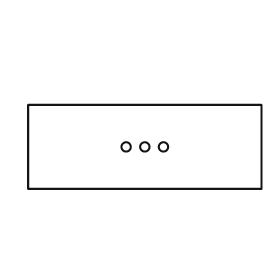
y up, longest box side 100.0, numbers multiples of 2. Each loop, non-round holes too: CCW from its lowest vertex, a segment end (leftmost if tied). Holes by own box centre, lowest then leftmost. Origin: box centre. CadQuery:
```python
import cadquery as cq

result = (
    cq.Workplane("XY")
    .moveTo(-50.0, -18.0)
    .lineTo(50.0, -18.0)
    .lineTo(50.0, 18.0)
    .lineTo(-50.0, 18.0)
    .close()
    .moveTo(-8.0, 0.0)
    .circle(2.0)
    .moveTo(0.0, 0.0)
    .circle(2.0)
    .moveTo(8.0, 0.0)
    .circle(2.0)
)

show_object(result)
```